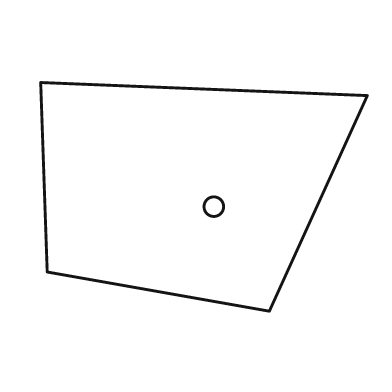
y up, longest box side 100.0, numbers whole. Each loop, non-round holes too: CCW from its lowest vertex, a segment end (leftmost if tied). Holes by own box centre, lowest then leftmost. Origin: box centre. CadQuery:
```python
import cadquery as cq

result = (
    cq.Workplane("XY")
    .moveTo(20.0, -35.0)
    .lineTo(50.0, 31.0)
    .lineTo(-50.0, 35.0)
    .lineTo(-48.0, -23.0)
    .close()
    .moveTo(3.0, -3.0)
    .circle(3.0)
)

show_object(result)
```